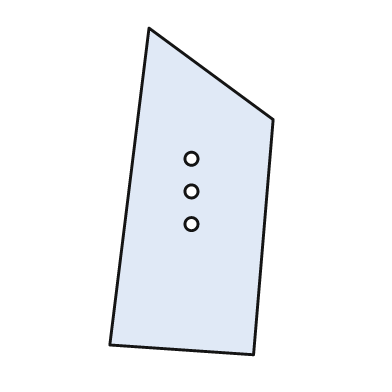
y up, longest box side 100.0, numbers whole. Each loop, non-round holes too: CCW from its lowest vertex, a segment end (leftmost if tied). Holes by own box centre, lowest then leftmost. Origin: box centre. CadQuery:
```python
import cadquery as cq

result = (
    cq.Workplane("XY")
    .moveTo(19.0, -50.0)
    .lineTo(25.0, 22.0)
    .lineTo(-13.0, 50.0)
    .lineTo(-25.0, -47.0)
    .close()
    .moveTo(0.0, -10.0)
    .circle(2.0)
    .moveTo(0.0, 0.0)
    .circle(2.0)
    .moveTo(0.0, 10.0)
    .circle(2.0)
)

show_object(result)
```